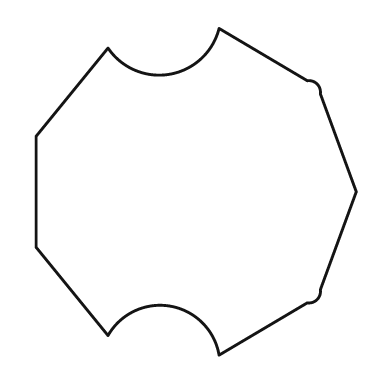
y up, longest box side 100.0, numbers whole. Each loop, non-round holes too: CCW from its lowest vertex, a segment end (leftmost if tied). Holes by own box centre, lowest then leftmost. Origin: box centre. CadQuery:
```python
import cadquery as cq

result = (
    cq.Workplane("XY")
    .moveTo(7.0, -50.0)
    .lineTo(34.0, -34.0)
    .threePointArc((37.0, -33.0), (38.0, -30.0))
    .lineTo(49.0, 0.0)
    .lineTo(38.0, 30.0)
    .threePointArc((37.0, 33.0), (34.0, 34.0))
    .lineTo(7.0, 50.0)
    .threePointArc((-8.0, 36.0), (-27.0, 44.0))
    .lineTo(-49.0, 17.0)
    .lineTo(-49.0, -17.0)
    .lineTo(-27.0, -44.0)
    .threePointArc((-8.0, -35.0), (7.0, -50.0))
    .close()
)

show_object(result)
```